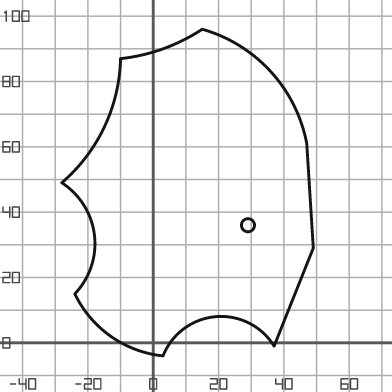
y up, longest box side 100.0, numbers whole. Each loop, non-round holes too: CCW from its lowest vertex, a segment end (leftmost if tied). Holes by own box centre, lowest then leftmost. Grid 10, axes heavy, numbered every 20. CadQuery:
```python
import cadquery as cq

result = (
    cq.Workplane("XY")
    .moveTo(3.0, -4.0)
    .threePointArc((19.0, 8.0), (37.0, -1.0))
    .lineTo(49.0, 29.0)
    .lineTo(47.0, 61.0)
    .threePointArc((36.0, 83.0), (15.0, 96.0))
    .threePointArc((3.0, 90.0), (-10.0, 87.0))
    .threePointArc((-15.0, 66.0), (-28.0, 49.0))
    .threePointArc((-18.0, 33.0), (-24.0, 15.0))
    .threePointArc((-13.0, 2.0), (3.0, -4.0))
    .close()
    .moveTo(29.0, 36.0)
    .circle(2.0)
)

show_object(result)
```